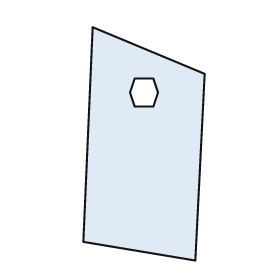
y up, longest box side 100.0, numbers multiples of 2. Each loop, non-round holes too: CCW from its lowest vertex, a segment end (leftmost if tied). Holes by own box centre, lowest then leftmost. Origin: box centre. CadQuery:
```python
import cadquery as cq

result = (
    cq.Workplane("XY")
    .moveTo(22.0, -50.0)
    .lineTo(26.0, 30.0)
    .lineTo(-22.0, 50.0)
    .lineTo(-26.0, -42.0)
    .close()
    .moveTo(-4.0, 16.0)
    .lineTo(4.0, 16.0)
    .lineTo(6.0, 22.0)
    .lineTo(4.0, 28.0)
    .lineTo(-4.0, 28.0)
    .lineTo(-6.0, 22.0)
    .close()
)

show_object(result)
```